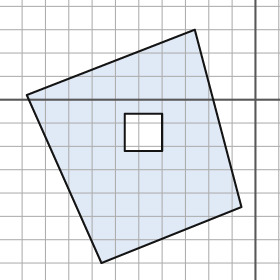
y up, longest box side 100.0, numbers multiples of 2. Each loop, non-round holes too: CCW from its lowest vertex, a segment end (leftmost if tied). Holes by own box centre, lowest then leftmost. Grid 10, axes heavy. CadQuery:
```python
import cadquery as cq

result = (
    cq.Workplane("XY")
    .moveTo(-66.0, -70.0)
    .lineTo(-6.0, -46.0)
    .lineTo(-26.0, 30.0)
    .lineTo(-98.0, 2.0)
    .close()
    .moveTo(-56.0, -22.0)
    .lineTo(-40.0, -22.0)
    .lineTo(-40.0, -6.0)
    .lineTo(-56.0, -6.0)
    .close()
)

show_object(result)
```